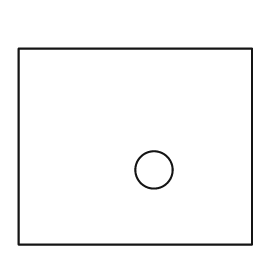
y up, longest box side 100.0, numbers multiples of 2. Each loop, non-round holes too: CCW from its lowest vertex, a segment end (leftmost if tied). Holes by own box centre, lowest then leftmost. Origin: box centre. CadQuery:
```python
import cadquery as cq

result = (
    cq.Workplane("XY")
    .moveTo(-50.0, -42.0)
    .lineTo(50.0, -42.0)
    .lineTo(50.0, 42.0)
    .lineTo(-50.0, 42.0)
    .close()
    .moveTo(8.0, -10.0)
    .circle(8.0)
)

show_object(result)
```